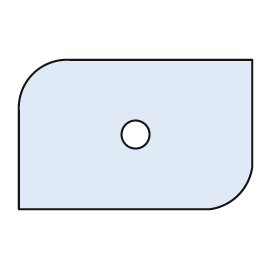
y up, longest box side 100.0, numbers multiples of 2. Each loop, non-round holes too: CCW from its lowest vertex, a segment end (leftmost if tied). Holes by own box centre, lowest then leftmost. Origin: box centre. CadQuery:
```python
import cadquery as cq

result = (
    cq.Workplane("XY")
    .moveTo(-50.0, -32.0)
    .lineTo(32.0, -32.0)
    .threePointArc((44.0, -26.0), (50.0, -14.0))
    .lineTo(50.0, 32.0)
    .lineTo(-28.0, 32.0)
    .threePointArc((-44.0, 26.0), (-50.0, 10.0))
    .close()
    .moveTo(0.0, 0.0)
    .circle(6.0)
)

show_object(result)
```